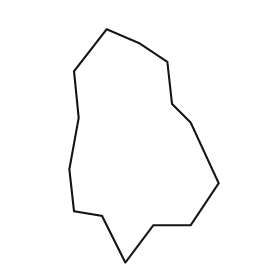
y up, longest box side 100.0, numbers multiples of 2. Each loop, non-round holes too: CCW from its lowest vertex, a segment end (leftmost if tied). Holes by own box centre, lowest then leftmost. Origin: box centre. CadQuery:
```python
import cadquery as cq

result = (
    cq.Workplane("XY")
    .moveTo(-8.0, -50.0)
    .lineTo(4.0, -34.0)
    .lineTo(20.0, -34.0)
    .lineTo(32.0, -16.0)
    .lineTo(20.0, 10.0)
    .lineTo(12.0, 18.0)
    .lineTo(10.0, 36.0)
    .lineTo(-2.0, 44.0)
    .lineTo(-16.0, 50.0)
    .lineTo(-30.0, 32.0)
    .lineTo(-28.0, 12.0)
    .lineTo(-32.0, -10.0)
    .lineTo(-30.0, -28.0)
    .lineTo(-18.0, -30.0)
    .close()
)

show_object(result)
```